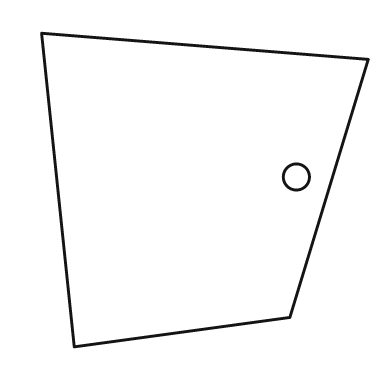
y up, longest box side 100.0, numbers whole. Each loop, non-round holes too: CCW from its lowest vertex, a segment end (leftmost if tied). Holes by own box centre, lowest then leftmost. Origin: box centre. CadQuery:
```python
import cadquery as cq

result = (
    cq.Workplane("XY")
    .moveTo(-40.0, -48.0)
    .lineTo(26.0, -39.0)
    .lineTo(50.0, 40.0)
    .lineTo(-50.0, 48.0)
    .close()
    .moveTo(28.0, 4.0)
    .circle(4.0)
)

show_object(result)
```